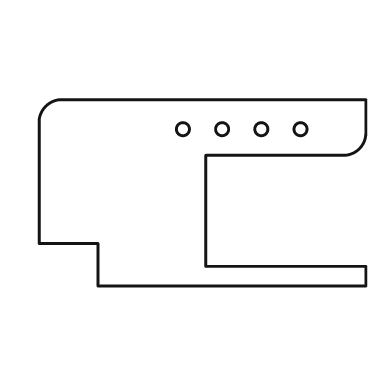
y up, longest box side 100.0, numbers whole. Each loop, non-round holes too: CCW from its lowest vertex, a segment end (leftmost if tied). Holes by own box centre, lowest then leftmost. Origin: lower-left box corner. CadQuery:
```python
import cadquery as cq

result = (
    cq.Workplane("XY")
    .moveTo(18.0, 0.0)
    .lineTo(100.0, 0.0)
    .lineTo(100.0, 6.0)
    .lineTo(51.0, 6.0)
    .lineTo(51.0, 40.0)
    .lineTo(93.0, 40.0)
    .threePointArc((98.0, 42.0), (100.0, 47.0))
    .lineTo(100.0, 57.0)
    .lineTo(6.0, 57.0)
    .threePointArc((2.0, 55.0), (0.0, 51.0))
    .lineTo(0.0, 13.0)
    .lineTo(18.0, 13.0)
    .close()
    .moveTo(44.0, 48.0)
    .circle(2.0)
    .moveTo(56.0, 48.0)
    .circle(2.0)
    .moveTo(68.0, 48.0)
    .circle(2.0)
    .moveTo(80.0, 48.0)
    .circle(2.0)
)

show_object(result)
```